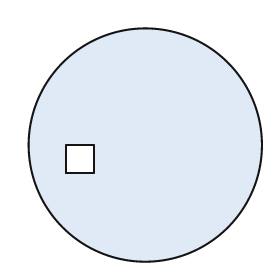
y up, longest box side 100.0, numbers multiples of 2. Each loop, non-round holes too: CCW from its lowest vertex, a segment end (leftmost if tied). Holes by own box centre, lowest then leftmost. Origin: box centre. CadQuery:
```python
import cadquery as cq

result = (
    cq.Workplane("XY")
    .moveTo(0.0, 0.0)
    .circle(50.0)
    .moveTo(-34.0, -12.0)
    .lineTo(-22.0, -12.0)
    .lineTo(-22.0, 0.0)
    .lineTo(-34.0, 0.0)
    .close()
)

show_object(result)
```